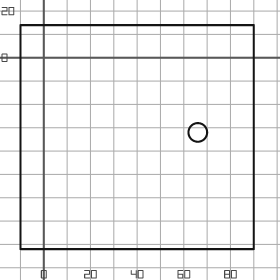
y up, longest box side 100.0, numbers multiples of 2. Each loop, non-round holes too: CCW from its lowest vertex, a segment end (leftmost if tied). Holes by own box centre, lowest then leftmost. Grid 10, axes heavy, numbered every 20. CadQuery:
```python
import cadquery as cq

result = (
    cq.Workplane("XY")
    .moveTo(-10.0, -82.0)
    .lineTo(90.0, -82.0)
    .lineTo(90.0, 14.0)
    .lineTo(-10.0, 14.0)
    .close()
    .moveTo(66.0, -32.0)
    .circle(4.0)
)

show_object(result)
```